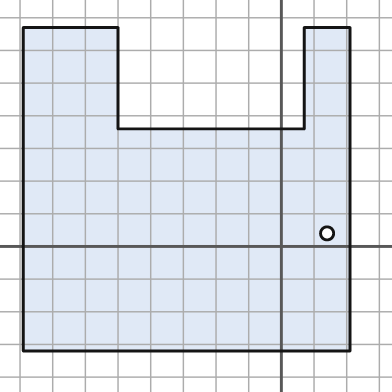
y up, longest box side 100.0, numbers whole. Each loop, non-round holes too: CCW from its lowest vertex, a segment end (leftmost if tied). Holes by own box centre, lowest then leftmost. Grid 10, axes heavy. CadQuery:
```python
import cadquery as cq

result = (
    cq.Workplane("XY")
    .moveTo(-79.0, -32.0)
    .lineTo(21.0, -32.0)
    .lineTo(21.0, 67.0)
    .lineTo(7.0, 67.0)
    .lineTo(7.0, 36.0)
    .lineTo(-50.0, 36.0)
    .lineTo(-50.0, 67.0)
    .lineTo(-79.0, 67.0)
    .close()
    .moveTo(14.0, 4.0)
    .circle(2.0)
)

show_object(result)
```